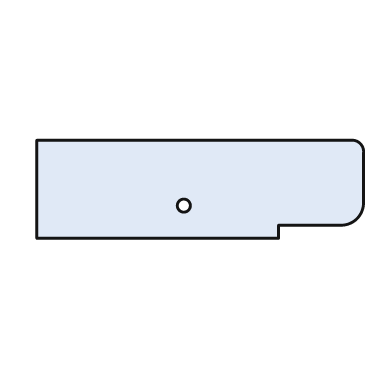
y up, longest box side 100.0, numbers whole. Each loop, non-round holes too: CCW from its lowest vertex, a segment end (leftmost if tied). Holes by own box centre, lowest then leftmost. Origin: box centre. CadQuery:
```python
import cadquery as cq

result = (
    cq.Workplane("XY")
    .moveTo(-50.0, -15.0)
    .lineTo(24.0, -15.0)
    .lineTo(24.0, -11.0)
    .lineTo(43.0, -11.0)
    .threePointArc((48.0, -9.0), (50.0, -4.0))
    .lineTo(50.0, 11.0)
    .threePointArc((49.0, 14.0), (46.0, 15.0))
    .lineTo(-50.0, 15.0)
    .close()
    .moveTo(-5.0, -5.0)
    .circle(2.0)
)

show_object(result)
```